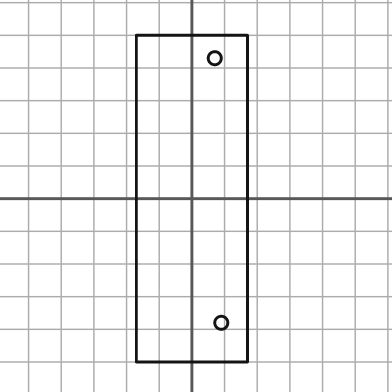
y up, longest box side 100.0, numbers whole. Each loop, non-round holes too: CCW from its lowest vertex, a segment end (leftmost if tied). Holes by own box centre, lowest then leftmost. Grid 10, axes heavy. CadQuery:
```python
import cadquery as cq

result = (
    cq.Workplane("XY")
    .moveTo(-17.0, -50.0)
    .lineTo(17.0, -50.0)
    .lineTo(17.0, 50.0)
    .lineTo(-17.0, 50.0)
    .close()
    .moveTo(9.0, -38.0)
    .circle(2.0)
    .moveTo(7.0, 43.0)
    .circle(2.0)
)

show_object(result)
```